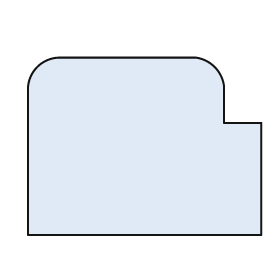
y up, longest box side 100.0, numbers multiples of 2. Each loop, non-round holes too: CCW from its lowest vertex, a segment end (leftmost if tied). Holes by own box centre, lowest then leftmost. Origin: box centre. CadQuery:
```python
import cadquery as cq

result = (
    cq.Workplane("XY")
    .moveTo(-50.0, -38.0)
    .lineTo(50.0, -38.0)
    .lineTo(50.0, 10.0)
    .lineTo(34.0, 10.0)
    .lineTo(34.0, 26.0)
    .threePointArc((30.0, 34.0), (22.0, 38.0))
    .lineTo(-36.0, 38.0)
    .threePointArc((-46.0, 34.0), (-50.0, 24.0))
    .close()
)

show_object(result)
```